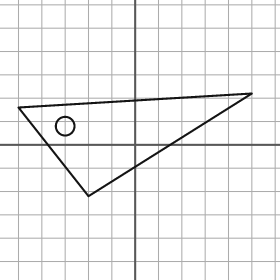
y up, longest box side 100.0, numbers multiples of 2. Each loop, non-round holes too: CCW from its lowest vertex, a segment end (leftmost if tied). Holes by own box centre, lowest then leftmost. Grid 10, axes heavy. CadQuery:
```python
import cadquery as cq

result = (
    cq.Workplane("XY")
    .moveTo(-20.0, -22.0)
    .lineTo(50.0, 22.0)
    .lineTo(-50.0, 16.0)
    .close()
    .moveTo(-30.0, 8.0)
    .circle(4.0)
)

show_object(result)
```